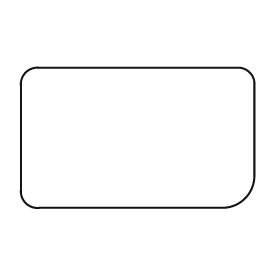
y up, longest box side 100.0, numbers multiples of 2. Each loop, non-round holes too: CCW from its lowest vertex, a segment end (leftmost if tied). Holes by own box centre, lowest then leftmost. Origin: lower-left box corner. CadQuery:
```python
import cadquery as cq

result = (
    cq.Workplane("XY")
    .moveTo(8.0, 0.0)
    .lineTo(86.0, 0.0)
    .threePointArc((96.0, 4.0), (100.0, 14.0))
    .lineTo(100.0, 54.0)
    .threePointArc((98.0, 58.0), (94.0, 60.0))
    .lineTo(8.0, 60.0)
    .threePointArc((2.0, 58.0), (0.0, 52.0))
    .lineTo(0.0, 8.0)
    .threePointArc((2.0, 2.0), (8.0, 0.0))
    .close()
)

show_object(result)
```